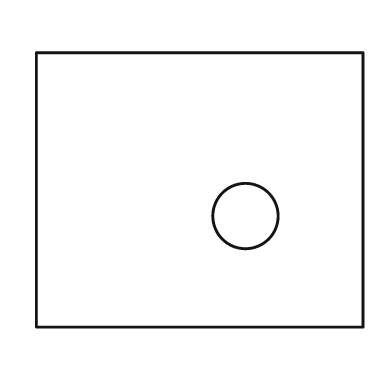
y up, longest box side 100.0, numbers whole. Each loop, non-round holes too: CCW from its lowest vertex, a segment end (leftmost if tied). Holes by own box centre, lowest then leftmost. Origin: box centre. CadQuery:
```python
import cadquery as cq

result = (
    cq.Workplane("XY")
    .moveTo(-50.0, -42.0)
    .lineTo(50.0, -42.0)
    .lineTo(50.0, 42.0)
    .lineTo(-50.0, 42.0)
    .close()
    .moveTo(14.0, -8.0)
    .circle(10.0)
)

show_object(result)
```